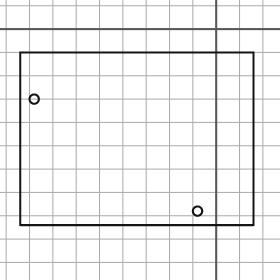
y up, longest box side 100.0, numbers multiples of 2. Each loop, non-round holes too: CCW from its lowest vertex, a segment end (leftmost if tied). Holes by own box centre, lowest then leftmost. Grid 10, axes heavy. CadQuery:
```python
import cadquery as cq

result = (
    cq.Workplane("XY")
    .moveTo(-84.0, -84.0)
    .lineTo(16.0, -84.0)
    .lineTo(16.0, -10.0)
    .lineTo(-84.0, -10.0)
    .close()
    .moveTo(-8.0, -78.0)
    .circle(2.0)
    .moveTo(-78.0, -30.0)
    .circle(2.0)
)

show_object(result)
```